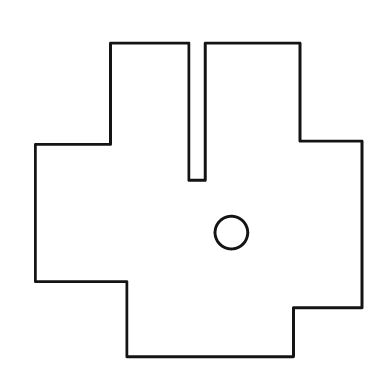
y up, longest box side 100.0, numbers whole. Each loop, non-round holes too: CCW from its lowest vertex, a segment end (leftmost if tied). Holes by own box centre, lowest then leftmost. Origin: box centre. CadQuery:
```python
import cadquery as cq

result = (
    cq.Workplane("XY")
    .moveTo(-22.0, -48.0)
    .lineTo(29.0, -48.0)
    .lineTo(29.0, -33.0)
    .lineTo(50.0, -33.0)
    .lineTo(50.0, 18.0)
    .lineTo(31.0, 18.0)
    .lineTo(31.0, 48.0)
    .lineTo(2.0, 48.0)
    .lineTo(2.0, 6.0)
    .lineTo(-3.0, 6.0)
    .lineTo(-3.0, 48.0)
    .lineTo(-27.0, 48.0)
    .lineTo(-27.0, 17.0)
    .lineTo(-50.0, 17.0)
    .lineTo(-50.0, -25.0)
    .lineTo(-22.0, -25.0)
    .close()
    .moveTo(10.0, -10.0)
    .circle(5.0)
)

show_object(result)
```